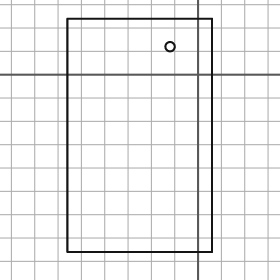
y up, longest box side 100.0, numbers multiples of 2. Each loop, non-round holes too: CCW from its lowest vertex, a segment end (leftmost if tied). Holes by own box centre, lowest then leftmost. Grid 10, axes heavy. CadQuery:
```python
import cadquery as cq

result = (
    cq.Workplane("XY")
    .moveTo(-56.0, -76.0)
    .lineTo(6.0, -76.0)
    .lineTo(6.0, 24.0)
    .lineTo(-56.0, 24.0)
    .close()
    .moveTo(-12.0, 12.0)
    .circle(2.0)
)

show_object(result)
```